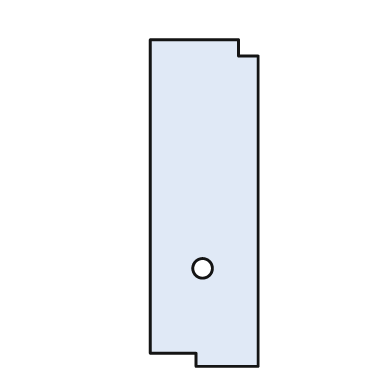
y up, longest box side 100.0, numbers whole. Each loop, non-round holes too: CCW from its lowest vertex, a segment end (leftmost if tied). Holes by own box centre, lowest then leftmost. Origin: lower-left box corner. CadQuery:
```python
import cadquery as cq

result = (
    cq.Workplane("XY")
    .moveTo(14.0, 0.0)
    .lineTo(33.0, 0.0)
    .lineTo(33.0, 95.0)
    .lineTo(27.0, 95.0)
    .lineTo(27.0, 100.0)
    .lineTo(0.0, 100.0)
    .lineTo(0.0, 4.0)
    .lineTo(14.0, 4.0)
    .close()
    .moveTo(16.0, 30.0)
    .circle(3.0)
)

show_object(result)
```